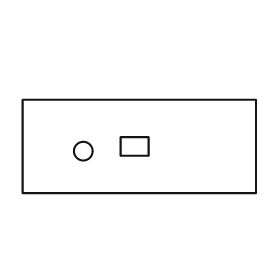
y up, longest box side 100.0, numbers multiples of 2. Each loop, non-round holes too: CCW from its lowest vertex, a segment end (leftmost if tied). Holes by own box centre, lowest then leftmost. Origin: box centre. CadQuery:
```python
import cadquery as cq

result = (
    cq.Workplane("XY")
    .moveTo(-50.0, -20.0)
    .lineTo(50.0, -20.0)
    .lineTo(50.0, 20.0)
    .lineTo(-50.0, 20.0)
    .close()
    .moveTo(-24.0, -2.0)
    .circle(4.0)
    .moveTo(-8.0, -4.0)
    .lineTo(4.0, -4.0)
    .lineTo(4.0, 4.0)
    .lineTo(-8.0, 4.0)
    .close()
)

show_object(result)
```